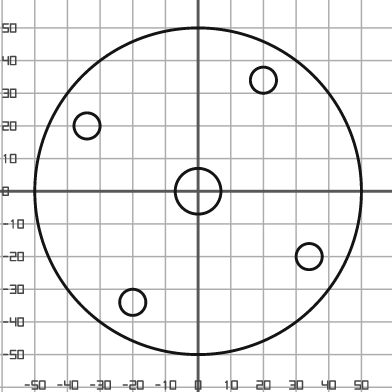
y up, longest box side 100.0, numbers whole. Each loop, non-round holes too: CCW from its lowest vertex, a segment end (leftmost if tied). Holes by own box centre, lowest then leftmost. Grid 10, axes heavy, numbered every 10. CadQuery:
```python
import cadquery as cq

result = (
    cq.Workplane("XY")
    .moveTo(0.0, 0.0)
    .circle(50.0)
    .moveTo(-20.0, -34.0)
    .circle(4.0)
    .moveTo(34.0, -20.0)
    .circle(4.0)
    .moveTo(0.0, 0.0)
    .circle(7.0)
    .moveTo(-34.0, 20.0)
    .circle(4.0)
    .moveTo(20.0, 34.0)
    .circle(4.0)
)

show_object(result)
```